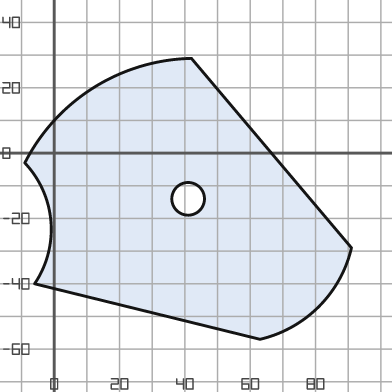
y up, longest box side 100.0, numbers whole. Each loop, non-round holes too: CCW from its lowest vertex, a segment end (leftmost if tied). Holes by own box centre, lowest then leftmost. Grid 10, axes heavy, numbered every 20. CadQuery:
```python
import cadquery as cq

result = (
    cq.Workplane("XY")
    .moveTo(63.0, -57.0)
    .threePointArc((81.0, -47.0), (91.0, -29.0))
    .lineTo(42.0, 29.0)
    .threePointArc((12.0, 20.0), (-9.0, -3.0))
    .threePointArc((-1.0, -21.0), (-6.0, -40.0))
    .close()
    .moveTo(41.0, -14.0)
    .circle(5.0)
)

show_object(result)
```